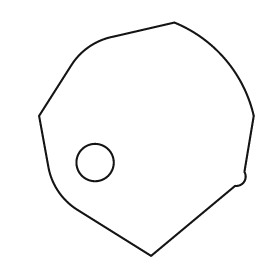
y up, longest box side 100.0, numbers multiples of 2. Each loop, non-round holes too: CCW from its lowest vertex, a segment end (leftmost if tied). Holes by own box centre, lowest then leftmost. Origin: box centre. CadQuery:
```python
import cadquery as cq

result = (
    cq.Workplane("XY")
    .moveTo(2.0, -50.0)
    .lineTo(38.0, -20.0)
    .threePointArc((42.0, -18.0), (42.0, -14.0))
    .lineTo(46.0, 10.0)
    .threePointArc((34.0, 34.0), (12.0, 50.0))
    .lineTo(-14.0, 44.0)
    .threePointArc((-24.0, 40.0), (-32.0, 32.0))
    .lineTo(-46.0, 10.0)
    .lineTo(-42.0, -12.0)
    .threePointArc((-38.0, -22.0), (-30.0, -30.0))
    .close()
    .moveTo(-22.0, -10.0)
    .circle(8.0)
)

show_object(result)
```